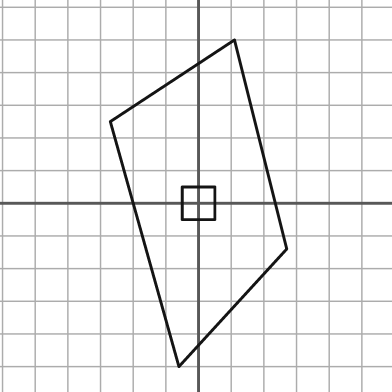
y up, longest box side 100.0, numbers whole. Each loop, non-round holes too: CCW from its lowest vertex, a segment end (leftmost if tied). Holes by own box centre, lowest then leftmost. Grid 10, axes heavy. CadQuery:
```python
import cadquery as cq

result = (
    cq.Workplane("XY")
    .moveTo(-6.0, -50.0)
    .lineTo(27.0, -14.0)
    .lineTo(11.0, 50.0)
    .lineTo(-27.0, 25.0)
    .close()
    .moveTo(-5.0, -5.0)
    .lineTo(5.0, -5.0)
    .lineTo(5.0, 5.0)
    .lineTo(-5.0, 5.0)
    .close()
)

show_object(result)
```